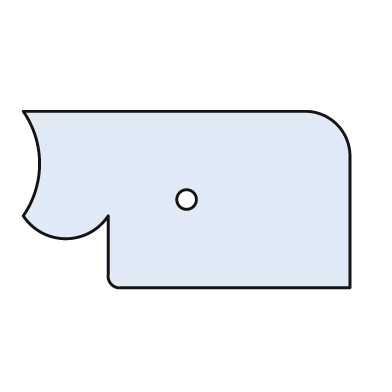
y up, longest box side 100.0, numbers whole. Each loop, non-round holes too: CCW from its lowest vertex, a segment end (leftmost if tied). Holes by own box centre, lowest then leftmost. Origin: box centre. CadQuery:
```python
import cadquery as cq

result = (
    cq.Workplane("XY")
    .moveTo(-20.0, -27.0)
    .lineTo(50.0, -27.0)
    .lineTo(50.0, 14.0)
    .threePointArc((46.0, 23.0), (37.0, 27.0))
    .lineTo(-50.0, 27.0)
    .threePointArc((-45.0, 11.0), (-50.0, -5.0))
    .threePointArc((-37.0, -12.0), (-24.0, -5.0))
    .lineTo(-24.0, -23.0)
    .threePointArc((-23.0, -26.0), (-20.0, -27.0))
    .close()
    .moveTo(0.0, 0.0)
    .circle(3.0)
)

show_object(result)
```